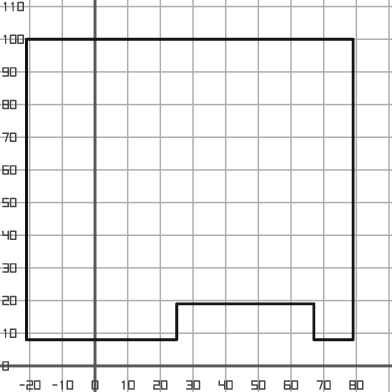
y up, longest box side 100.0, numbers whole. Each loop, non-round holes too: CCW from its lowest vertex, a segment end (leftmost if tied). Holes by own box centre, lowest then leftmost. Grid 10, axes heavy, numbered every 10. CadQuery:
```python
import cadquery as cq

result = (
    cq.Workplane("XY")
    .moveTo(-21.0, 8.0)
    .lineTo(25.0, 8.0)
    .lineTo(25.0, 19.0)
    .lineTo(67.0, 19.0)
    .lineTo(67.0, 8.0)
    .lineTo(79.0, 8.0)
    .lineTo(79.0, 100.0)
    .lineTo(-21.0, 100.0)
    .close()
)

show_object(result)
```